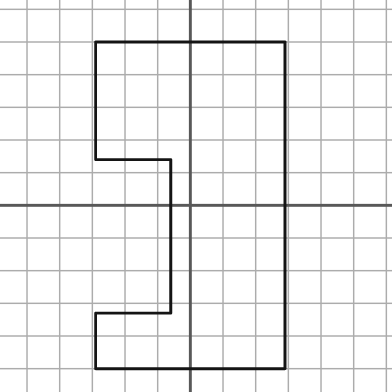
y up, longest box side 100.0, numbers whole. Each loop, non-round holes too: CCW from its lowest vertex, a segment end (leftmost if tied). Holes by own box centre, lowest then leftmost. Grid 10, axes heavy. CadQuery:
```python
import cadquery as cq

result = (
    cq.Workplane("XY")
    .moveTo(-29.0, -50.0)
    .lineTo(29.0, -50.0)
    .lineTo(29.0, 50.0)
    .lineTo(-29.0, 50.0)
    .lineTo(-29.0, 14.0)
    .lineTo(-6.0, 14.0)
    .lineTo(-6.0, -33.0)
    .lineTo(-29.0, -33.0)
    .close()
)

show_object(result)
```